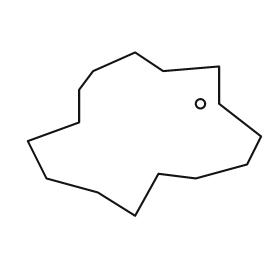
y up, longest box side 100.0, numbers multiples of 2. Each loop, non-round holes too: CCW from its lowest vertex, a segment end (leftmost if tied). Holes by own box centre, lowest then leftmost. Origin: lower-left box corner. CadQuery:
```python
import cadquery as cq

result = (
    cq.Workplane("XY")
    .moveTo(46.0, 0.0)
    .lineTo(56.0, 18.0)
    .lineTo(72.0, 16.0)
    .lineTo(94.0, 22.0)
    .lineTo(100.0, 34.0)
    .lineTo(82.0, 48.0)
    .lineTo(82.0, 64.0)
    .lineTo(58.0, 62.0)
    .lineTo(46.0, 70.0)
    .lineTo(28.0, 62.0)
    .lineTo(22.0, 54.0)
    .lineTo(22.0, 40.0)
    .lineTo(0.0, 32.0)
    .lineTo(8.0, 16.0)
    .lineTo(30.0, 10.0)
    .close()
    .moveTo(74.0, 48.0)
    .circle(2.0)
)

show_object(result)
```